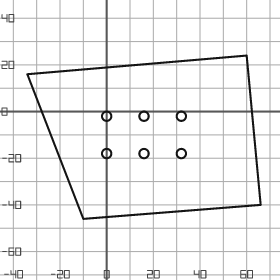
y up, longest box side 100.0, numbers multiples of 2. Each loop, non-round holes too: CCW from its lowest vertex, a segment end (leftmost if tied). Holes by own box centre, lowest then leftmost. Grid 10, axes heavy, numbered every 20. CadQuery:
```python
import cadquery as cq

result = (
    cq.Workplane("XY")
    .moveTo(-10.0, -46.0)
    .lineTo(66.0, -40.0)
    .lineTo(60.0, 24.0)
    .lineTo(-34.0, 16.0)
    .close()
    .moveTo(0.0, -18.0)
    .circle(2.0)
    .moveTo(16.0, -18.0)
    .circle(2.0)
    .moveTo(32.0, -18.0)
    .circle(2.0)
    .moveTo(0.0, -2.0)
    .circle(2.0)
    .moveTo(16.0, -2.0)
    .circle(2.0)
    .moveTo(32.0, -2.0)
    .circle(2.0)
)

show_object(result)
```